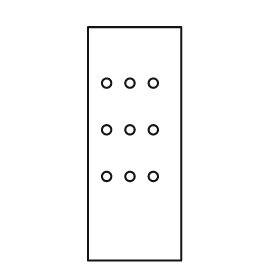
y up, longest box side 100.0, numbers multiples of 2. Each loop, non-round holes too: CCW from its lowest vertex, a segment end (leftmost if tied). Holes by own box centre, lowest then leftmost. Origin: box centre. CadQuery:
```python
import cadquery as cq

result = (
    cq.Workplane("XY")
    .moveTo(-20.0, -50.0)
    .lineTo(20.0, -50.0)
    .lineTo(20.0, 50.0)
    .lineTo(-20.0, 50.0)
    .close()
    .moveTo(-12.0, -14.0)
    .circle(2.0)
    .moveTo(-2.0, -14.0)
    .circle(2.0)
    .moveTo(8.0, -14.0)
    .circle(2.0)
    .moveTo(-12.0, 6.0)
    .circle(2.0)
    .moveTo(-2.0, 6.0)
    .circle(2.0)
    .moveTo(8.0, 6.0)
    .circle(2.0)
    .moveTo(-12.0, 26.0)
    .circle(2.0)
    .moveTo(-2.0, 26.0)
    .circle(2.0)
    .moveTo(8.0, 26.0)
    .circle(2.0)
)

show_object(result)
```